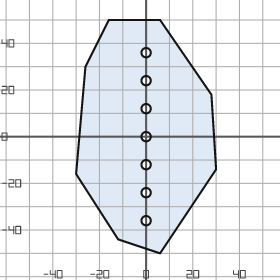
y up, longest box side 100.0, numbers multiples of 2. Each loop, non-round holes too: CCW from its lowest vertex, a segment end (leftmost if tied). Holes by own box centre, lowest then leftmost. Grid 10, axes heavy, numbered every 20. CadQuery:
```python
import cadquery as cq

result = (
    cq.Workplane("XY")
    .moveTo(6.0, -50.0)
    .lineTo(30.0, -14.0)
    .lineTo(28.0, 18.0)
    .lineTo(6.0, 50.0)
    .lineTo(-16.0, 50.0)
    .lineTo(-26.0, 30.0)
    .lineTo(-30.0, -16.0)
    .lineTo(-12.0, -44.0)
    .close()
    .moveTo(0.0, -36.0)
    .circle(2.0)
    .moveTo(0.0, -24.0)
    .circle(2.0)
    .moveTo(0.0, -12.0)
    .circle(2.0)
    .moveTo(0.0, 0.0)
    .circle(2.0)
    .moveTo(0.0, 12.0)
    .circle(2.0)
    .moveTo(0.0, 24.0)
    .circle(2.0)
    .moveTo(0.0, 36.0)
    .circle(2.0)
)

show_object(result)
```